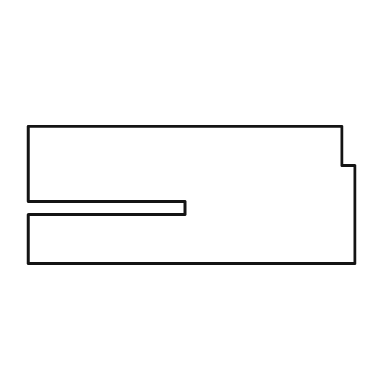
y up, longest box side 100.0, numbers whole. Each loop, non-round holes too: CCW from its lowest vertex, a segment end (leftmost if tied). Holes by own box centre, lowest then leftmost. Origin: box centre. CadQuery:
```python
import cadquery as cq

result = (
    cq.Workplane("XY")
    .moveTo(-50.0, -21.0)
    .lineTo(50.0, -21.0)
    .lineTo(50.0, 9.0)
    .lineTo(46.0, 9.0)
    .lineTo(46.0, 21.0)
    .lineTo(-50.0, 21.0)
    .lineTo(-50.0, -2.0)
    .lineTo(-2.0, -2.0)
    .lineTo(-2.0, -6.0)
    .lineTo(-50.0, -6.0)
    .close()
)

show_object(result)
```